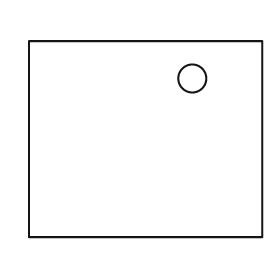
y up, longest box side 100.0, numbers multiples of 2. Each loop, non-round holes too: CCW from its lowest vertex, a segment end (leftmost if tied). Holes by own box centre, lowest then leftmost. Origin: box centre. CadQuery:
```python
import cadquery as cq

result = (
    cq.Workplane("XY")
    .moveTo(-50.0, -42.0)
    .lineTo(50.0, -42.0)
    .lineTo(50.0, 42.0)
    .lineTo(-50.0, 42.0)
    .close()
    .moveTo(20.0, 26.0)
    .circle(6.0)
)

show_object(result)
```